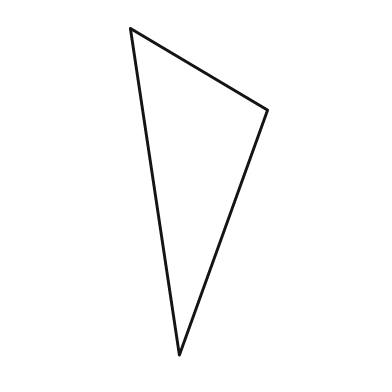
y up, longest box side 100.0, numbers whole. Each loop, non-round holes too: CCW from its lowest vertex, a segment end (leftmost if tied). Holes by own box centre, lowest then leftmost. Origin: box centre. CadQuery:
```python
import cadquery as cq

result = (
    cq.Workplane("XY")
    .moveTo(-6.0, -50.0)
    .lineTo(21.0, 25.0)
    .lineTo(-21.0, 50.0)
    .close()
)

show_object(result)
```